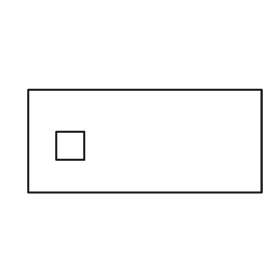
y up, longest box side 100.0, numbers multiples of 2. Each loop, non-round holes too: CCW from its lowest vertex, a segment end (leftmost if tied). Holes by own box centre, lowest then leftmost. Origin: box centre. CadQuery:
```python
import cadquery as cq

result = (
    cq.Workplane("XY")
    .moveTo(-50.0, -22.0)
    .lineTo(50.0, -22.0)
    .lineTo(50.0, 22.0)
    .lineTo(-50.0, 22.0)
    .close()
    .moveTo(-38.0, -8.0)
    .lineTo(-26.0, -8.0)
    .lineTo(-26.0, 4.0)
    .lineTo(-38.0, 4.0)
    .close()
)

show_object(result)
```